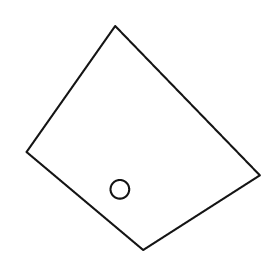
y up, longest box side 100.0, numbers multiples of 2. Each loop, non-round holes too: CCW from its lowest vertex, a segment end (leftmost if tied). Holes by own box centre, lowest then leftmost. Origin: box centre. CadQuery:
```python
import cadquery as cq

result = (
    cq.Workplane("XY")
    .moveTo(0.0, -48.0)
    .lineTo(50.0, -16.0)
    .lineTo(-12.0, 48.0)
    .lineTo(-50.0, -6.0)
    .close()
    .moveTo(-10.0, -22.0)
    .circle(4.0)
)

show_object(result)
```